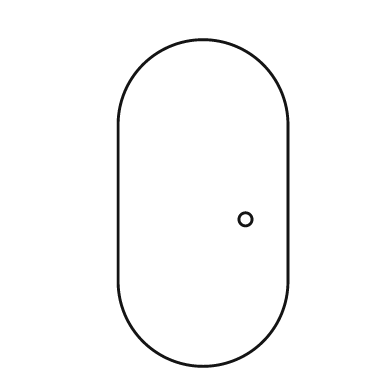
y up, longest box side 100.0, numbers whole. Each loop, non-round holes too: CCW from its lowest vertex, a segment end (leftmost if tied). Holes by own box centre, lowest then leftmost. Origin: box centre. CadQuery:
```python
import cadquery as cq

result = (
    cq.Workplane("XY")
    .moveTo(-26.0, -24.0)
    .threePointArc((0.0, -50.0), (26.0, -24.0))
    .lineTo(26.0, 24.0)
    .threePointArc((0.0, 50.0), (-26.0, 24.0))
    .close()
    .moveTo(13.0, -5.0)
    .circle(2.0)
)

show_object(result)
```